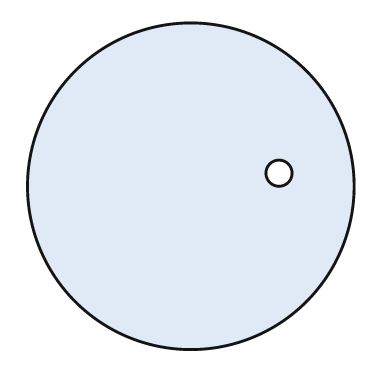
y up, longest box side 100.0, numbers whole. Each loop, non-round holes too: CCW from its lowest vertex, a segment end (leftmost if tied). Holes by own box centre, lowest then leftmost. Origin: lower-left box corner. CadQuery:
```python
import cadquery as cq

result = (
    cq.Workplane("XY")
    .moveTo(50.0, 50.0)
    .circle(50.0)
    .moveTo(77.0, 54.0)
    .circle(4.0)
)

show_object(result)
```